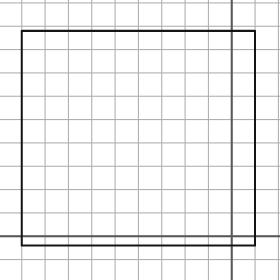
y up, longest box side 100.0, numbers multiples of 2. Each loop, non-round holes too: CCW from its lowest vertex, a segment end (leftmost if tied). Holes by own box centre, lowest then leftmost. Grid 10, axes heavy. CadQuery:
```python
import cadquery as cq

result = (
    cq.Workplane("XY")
    .moveTo(-90.0, -4.0)
    .lineTo(10.0, -4.0)
    .lineTo(10.0, 88.0)
    .lineTo(-90.0, 88.0)
    .close()
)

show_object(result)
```